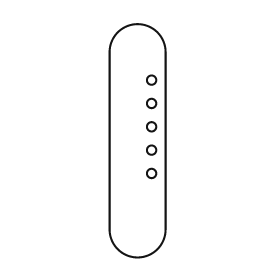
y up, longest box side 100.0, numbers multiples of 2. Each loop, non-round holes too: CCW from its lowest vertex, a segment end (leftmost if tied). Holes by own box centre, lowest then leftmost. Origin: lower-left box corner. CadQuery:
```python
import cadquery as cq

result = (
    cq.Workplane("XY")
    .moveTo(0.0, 12.0)
    .threePointArc((12.0, 0.0), (24.0, 12.0))
    .lineTo(24.0, 88.0)
    .threePointArc((12.0, 100.0), (0.0, 88.0))
    .close()
    .moveTo(18.0, 36.0)
    .circle(2.0)
    .moveTo(18.0, 46.0)
    .circle(2.0)
    .moveTo(18.0, 56.0)
    .circle(2.0)
    .moveTo(18.0, 66.0)
    .circle(2.0)
    .moveTo(18.0, 76.0)
    .circle(2.0)
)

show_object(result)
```